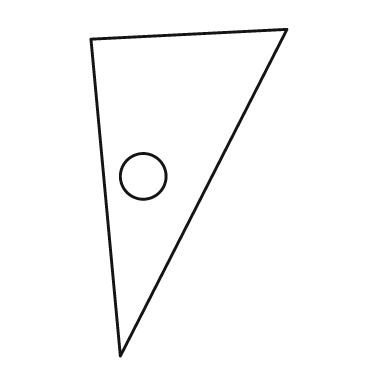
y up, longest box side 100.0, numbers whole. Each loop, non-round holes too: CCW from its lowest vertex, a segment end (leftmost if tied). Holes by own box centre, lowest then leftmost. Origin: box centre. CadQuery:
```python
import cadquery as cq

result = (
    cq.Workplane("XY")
    .moveTo(-21.0, -50.0)
    .lineTo(30.0, 50.0)
    .lineTo(-30.0, 47.0)
    .close()
    .moveTo(-14.0, 5.0)
    .circle(7.0)
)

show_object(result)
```